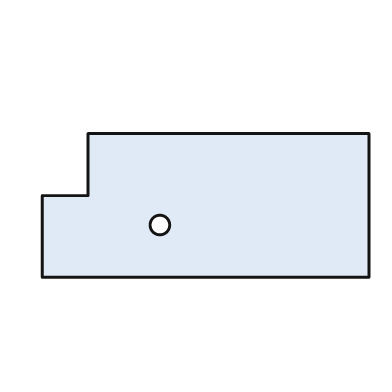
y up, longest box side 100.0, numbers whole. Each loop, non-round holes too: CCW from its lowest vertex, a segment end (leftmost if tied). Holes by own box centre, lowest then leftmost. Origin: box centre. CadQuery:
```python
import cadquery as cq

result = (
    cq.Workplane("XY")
    .moveTo(-50.0, -22.0)
    .lineTo(50.0, -22.0)
    .lineTo(50.0, 22.0)
    .lineTo(-36.0, 22.0)
    .lineTo(-36.0, 3.0)
    .lineTo(-50.0, 3.0)
    .close()
    .moveTo(-14.0, -6.0)
    .circle(3.0)
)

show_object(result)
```